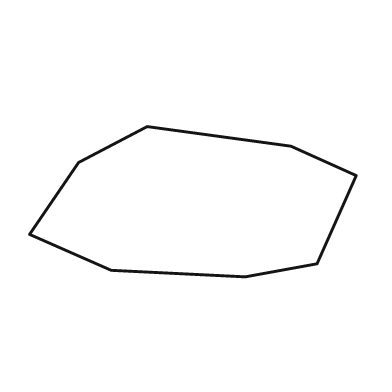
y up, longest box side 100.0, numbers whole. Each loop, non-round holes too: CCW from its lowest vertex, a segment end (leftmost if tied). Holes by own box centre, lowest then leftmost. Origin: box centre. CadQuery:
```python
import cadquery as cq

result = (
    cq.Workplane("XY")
    .moveTo(16.0, -23.0)
    .lineTo(38.0, -19.0)
    .lineTo(50.0, 8.0)
    .lineTo(30.0, 17.0)
    .lineTo(-14.0, 23.0)
    .lineTo(-35.0, 12.0)
    .lineTo(-50.0, -10.0)
    .lineTo(-25.0, -21.0)
    .close()
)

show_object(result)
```